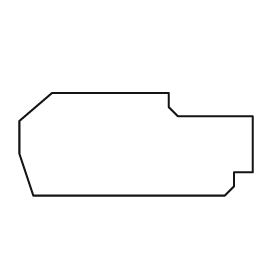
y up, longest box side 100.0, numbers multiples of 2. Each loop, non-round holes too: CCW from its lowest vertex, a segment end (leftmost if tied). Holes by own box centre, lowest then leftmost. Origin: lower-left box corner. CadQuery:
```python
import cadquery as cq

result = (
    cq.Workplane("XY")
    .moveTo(6.0, 0.0)
    .lineTo(88.0, 0.0)
    .lineTo(92.0, 4.0)
    .lineTo(92.0, 10.0)
    .lineTo(100.0, 10.0)
    .lineTo(100.0, 34.0)
    .lineTo(68.0, 34.0)
    .lineTo(64.0, 38.0)
    .lineTo(64.0, 44.0)
    .lineTo(14.0, 44.0)
    .lineTo(0.0, 32.0)
    .lineTo(0.0, 18.0)
    .close()
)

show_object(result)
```